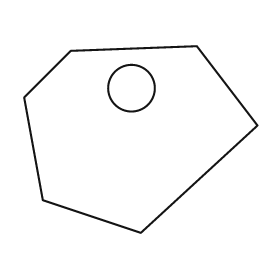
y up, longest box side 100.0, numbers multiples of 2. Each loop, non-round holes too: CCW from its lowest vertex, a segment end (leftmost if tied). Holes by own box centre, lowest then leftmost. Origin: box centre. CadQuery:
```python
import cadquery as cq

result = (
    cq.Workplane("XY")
    .moveTo(0.0, -40.0)
    .lineTo(50.0, 6.0)
    .lineTo(24.0, 40.0)
    .lineTo(-30.0, 38.0)
    .lineTo(-50.0, 18.0)
    .lineTo(-42.0, -26.0)
    .close()
    .moveTo(-4.0, 22.0)
    .circle(10.0)
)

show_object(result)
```